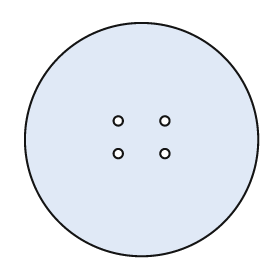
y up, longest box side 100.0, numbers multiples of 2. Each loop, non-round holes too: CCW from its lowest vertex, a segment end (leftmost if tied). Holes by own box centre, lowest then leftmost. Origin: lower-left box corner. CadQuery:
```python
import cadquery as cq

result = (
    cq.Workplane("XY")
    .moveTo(50.0, 50.0)
    .circle(50.0)
    .moveTo(40.0, 44.0)
    .circle(2.0)
    .moveTo(60.0, 44.0)
    .circle(2.0)
    .moveTo(40.0, 58.0)
    .circle(2.0)
    .moveTo(60.0, 58.0)
    .circle(2.0)
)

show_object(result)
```